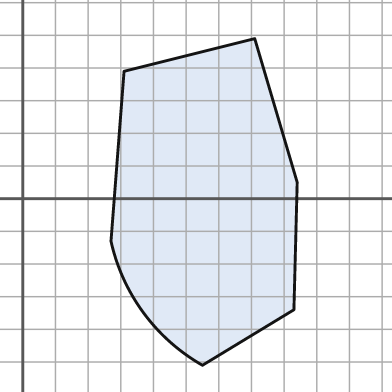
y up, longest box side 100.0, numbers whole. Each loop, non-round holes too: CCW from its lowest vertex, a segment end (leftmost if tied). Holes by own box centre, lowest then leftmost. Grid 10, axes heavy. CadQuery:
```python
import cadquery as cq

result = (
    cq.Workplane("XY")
    .moveTo(55.0, -51.0)
    .lineTo(83.0, -34.0)
    .lineTo(84.0, 5.0)
    .lineTo(71.0, 49.0)
    .lineTo(31.0, 39.0)
    .lineTo(27.0, -13.0)
    .threePointArc((37.0, -35.0), (55.0, -51.0))
    .close()
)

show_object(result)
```